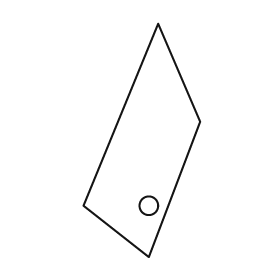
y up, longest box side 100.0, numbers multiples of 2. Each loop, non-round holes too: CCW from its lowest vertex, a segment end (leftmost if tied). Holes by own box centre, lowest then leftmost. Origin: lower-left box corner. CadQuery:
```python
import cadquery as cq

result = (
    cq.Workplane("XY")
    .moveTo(28.0, 0.0)
    .lineTo(50.0, 58.0)
    .lineTo(32.0, 100.0)
    .lineTo(0.0, 22.0)
    .close()
    .moveTo(28.0, 22.0)
    .circle(4.0)
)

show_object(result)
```